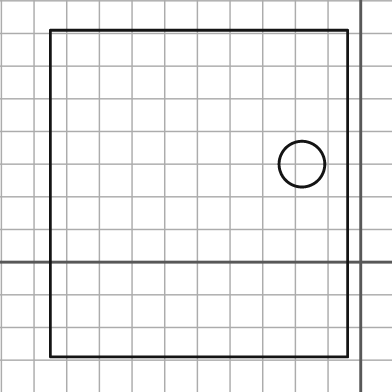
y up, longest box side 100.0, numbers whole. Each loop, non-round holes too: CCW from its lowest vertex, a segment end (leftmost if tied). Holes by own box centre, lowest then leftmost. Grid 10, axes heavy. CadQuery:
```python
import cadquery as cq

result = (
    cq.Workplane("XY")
    .moveTo(-95.0, -29.0)
    .lineTo(-4.0, -29.0)
    .lineTo(-4.0, 71.0)
    .lineTo(-95.0, 71.0)
    .close()
    .moveTo(-18.0, 30.0)
    .circle(7.0)
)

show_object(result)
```